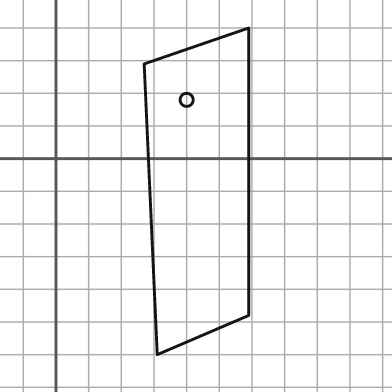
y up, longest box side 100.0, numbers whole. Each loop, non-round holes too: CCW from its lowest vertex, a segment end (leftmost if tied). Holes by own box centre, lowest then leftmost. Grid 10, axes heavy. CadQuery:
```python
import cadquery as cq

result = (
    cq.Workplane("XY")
    .moveTo(31.0, -60.0)
    .lineTo(59.0, -48.0)
    .lineTo(59.0, 40.0)
    .lineTo(27.0, 29.0)
    .close()
    .moveTo(40.0, 18.0)
    .circle(2.0)
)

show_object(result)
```